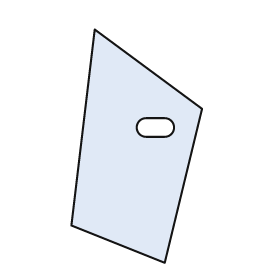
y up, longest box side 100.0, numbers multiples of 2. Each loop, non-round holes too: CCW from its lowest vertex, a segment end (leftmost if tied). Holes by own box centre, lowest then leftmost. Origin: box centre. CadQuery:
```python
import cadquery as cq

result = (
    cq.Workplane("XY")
    .moveTo(12.0, -50.0)
    .lineTo(28.0, 16.0)
    .lineTo(-18.0, 50.0)
    .lineTo(-28.0, -34.0)
    .close()
    .moveTo(4.0, 4.0)
    .lineTo(12.0, 4.0)
    .threePointArc((16.0, 8.0), (12.0, 12.0))
    .lineTo(4.0, 12.0)
    .threePointArc((0.0, 8.0), (4.0, 4.0))
    .close()
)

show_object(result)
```